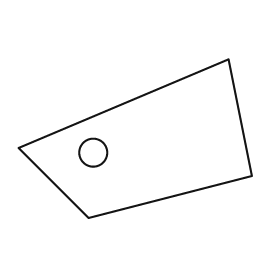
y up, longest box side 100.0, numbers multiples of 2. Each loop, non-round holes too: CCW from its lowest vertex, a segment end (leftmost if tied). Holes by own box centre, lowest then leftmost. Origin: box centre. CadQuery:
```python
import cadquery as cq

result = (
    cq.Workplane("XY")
    .moveTo(-20.0, -34.0)
    .lineTo(50.0, -16.0)
    .lineTo(40.0, 34.0)
    .lineTo(-50.0, -4.0)
    .close()
    .moveTo(-18.0, -6.0)
    .circle(6.0)
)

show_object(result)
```